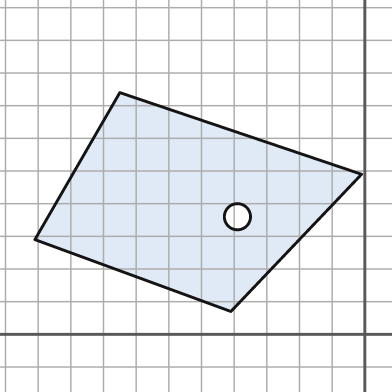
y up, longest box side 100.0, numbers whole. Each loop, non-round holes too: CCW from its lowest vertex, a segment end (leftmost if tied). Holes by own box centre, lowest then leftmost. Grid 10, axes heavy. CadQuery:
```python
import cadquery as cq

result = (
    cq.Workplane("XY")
    .moveTo(-41.0, 7.0)
    .lineTo(-1.0, 49.0)
    .lineTo(-75.0, 74.0)
    .lineTo(-101.0, 29.0)
    .close()
    .moveTo(-39.0, 36.0)
    .circle(4.0)
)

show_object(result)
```